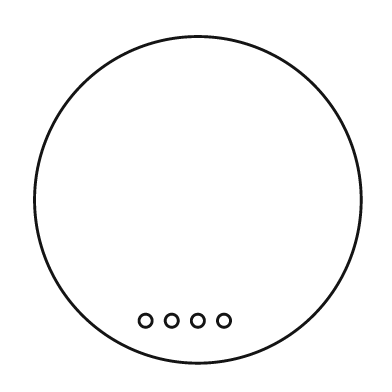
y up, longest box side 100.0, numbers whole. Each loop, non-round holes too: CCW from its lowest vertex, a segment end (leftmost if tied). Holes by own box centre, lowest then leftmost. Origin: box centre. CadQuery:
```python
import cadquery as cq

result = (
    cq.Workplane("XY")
    .moveTo(0.0, 0.0)
    .circle(50.0)
    .moveTo(-16.0, -37.0)
    .circle(2.0)
    .moveTo(-8.0, -37.0)
    .circle(2.0)
    .moveTo(0.0, -37.0)
    .circle(2.0)
    .moveTo(8.0, -37.0)
    .circle(2.0)
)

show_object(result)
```